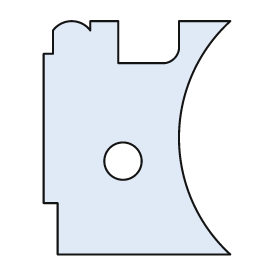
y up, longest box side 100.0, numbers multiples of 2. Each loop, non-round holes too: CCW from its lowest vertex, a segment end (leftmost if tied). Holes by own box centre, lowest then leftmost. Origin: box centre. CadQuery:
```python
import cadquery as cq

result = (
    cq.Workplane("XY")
    .moveTo(-34.0, -50.0)
    .lineTo(40.0, -50.0)
    .threePointArc((18.0, 0.0), (40.0, 50.0))
    .lineTo(18.0, 50.0)
    .lineTo(18.0, 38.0)
    .threePointArc((16.0, 34.0), (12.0, 32.0))
    .lineTo(-8.0, 32.0)
    .lineTo(-8.0, 50.0)
    .lineTo(-20.0, 50.0)
    .lineTo(-20.0, 46.0)
    .threePointArc((-28.0, 50.0), (-36.0, 46.0))
    .lineTo(-36.0, 36.0)
    .lineTo(-40.0, 36.0)
    .lineTo(-40.0, -28.0)
    .lineTo(-34.0, -28.0)
    .close()
    .moveTo(-6.0, -10.0)
    .circle(8.0)
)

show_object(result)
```